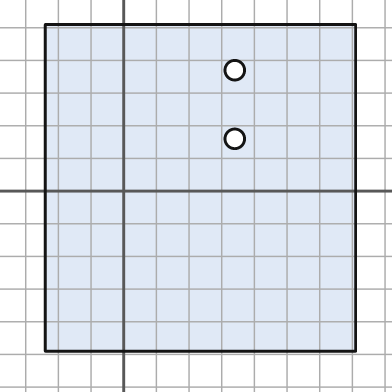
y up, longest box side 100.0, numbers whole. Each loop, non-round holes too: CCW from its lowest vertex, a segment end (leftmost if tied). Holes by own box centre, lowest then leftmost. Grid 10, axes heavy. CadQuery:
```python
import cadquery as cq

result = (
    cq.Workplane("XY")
    .moveTo(-24.0, -49.0)
    .lineTo(71.0, -49.0)
    .lineTo(71.0, 51.0)
    .lineTo(-24.0, 51.0)
    .close()
    .moveTo(34.0, 16.0)
    .circle(3.0)
    .moveTo(34.0, 37.0)
    .circle(3.0)
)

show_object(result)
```